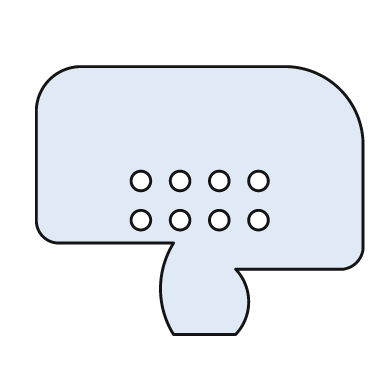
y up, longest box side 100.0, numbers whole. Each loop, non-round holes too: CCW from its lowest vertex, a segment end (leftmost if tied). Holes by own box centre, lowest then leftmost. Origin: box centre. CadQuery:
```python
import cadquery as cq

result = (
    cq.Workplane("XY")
    .moveTo(-8.0, -41.0)
    .lineTo(11.0, -41.0)
    .threePointArc((15.0, -31.0), (11.0, -21.0))
    .lineTo(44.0, -21.0)
    .threePointArc((48.0, -19.0), (50.0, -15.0))
    .lineTo(50.0, 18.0)
    .threePointArc((43.0, 34.0), (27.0, 41.0))
    .lineTo(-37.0, 41.0)
    .threePointArc((-46.0, 37.0), (-50.0, 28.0))
    .lineTo(-50.0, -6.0)
    .threePointArc((-48.0, -11.0), (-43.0, -13.0))
    .lineTo(-8.0, -13.0)
    .threePointArc((-12.0, -27.0), (-8.0, -41.0))
    .close()
    .moveTo(-18.0, -6.0)
    .circle(3.0)
    .moveTo(-6.0, -6.0)
    .circle(3.0)
    .moveTo(6.0, -6.0)
    .circle(3.0)
    .moveTo(18.0, -6.0)
    .circle(3.0)
    .moveTo(-18.0, 6.0)
    .circle(3.0)
    .moveTo(-6.0, 6.0)
    .circle(3.0)
    .moveTo(6.0, 6.0)
    .circle(3.0)
    .moveTo(18.0, 6.0)
    .circle(3.0)
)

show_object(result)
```